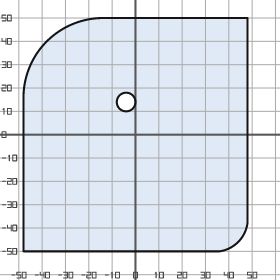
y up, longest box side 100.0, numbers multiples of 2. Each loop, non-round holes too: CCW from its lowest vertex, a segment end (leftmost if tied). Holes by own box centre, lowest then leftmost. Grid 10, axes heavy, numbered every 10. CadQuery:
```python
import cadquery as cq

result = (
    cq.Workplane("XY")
    .moveTo(-48.0, -50.0)
    .lineTo(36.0, -50.0)
    .threePointArc((44.0, -46.0), (48.0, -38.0))
    .lineTo(48.0, 50.0)
    .lineTo(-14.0, 50.0)
    .threePointArc((-38.0, 40.0), (-48.0, 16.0))
    .close()
    .moveTo(-4.0, 14.0)
    .circle(4.0)
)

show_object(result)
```